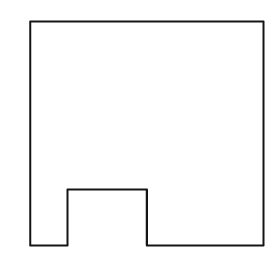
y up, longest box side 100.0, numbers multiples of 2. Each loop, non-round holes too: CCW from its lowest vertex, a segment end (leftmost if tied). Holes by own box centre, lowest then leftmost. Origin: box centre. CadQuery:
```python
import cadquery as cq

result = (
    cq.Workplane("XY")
    .moveTo(-50.0, -48.0)
    .lineTo(-34.0, -48.0)
    .lineTo(-34.0, -24.0)
    .lineTo(0.0, -24.0)
    .lineTo(0.0, -48.0)
    .lineTo(50.0, -48.0)
    .lineTo(50.0, 48.0)
    .lineTo(-50.0, 48.0)
    .close()
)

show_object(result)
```